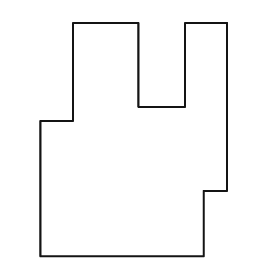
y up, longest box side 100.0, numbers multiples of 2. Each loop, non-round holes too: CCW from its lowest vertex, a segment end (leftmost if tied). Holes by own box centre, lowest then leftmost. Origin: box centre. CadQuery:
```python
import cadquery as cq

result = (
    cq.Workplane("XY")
    .moveTo(-40.0, -50.0)
    .lineTo(30.0, -50.0)
    .lineTo(30.0, -22.0)
    .lineTo(40.0, -22.0)
    .lineTo(40.0, 50.0)
    .lineTo(22.0, 50.0)
    .lineTo(22.0, 14.0)
    .lineTo(2.0, 14.0)
    .lineTo(2.0, 50.0)
    .lineTo(-26.0, 50.0)
    .lineTo(-26.0, 8.0)
    .lineTo(-40.0, 8.0)
    .close()
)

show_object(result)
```